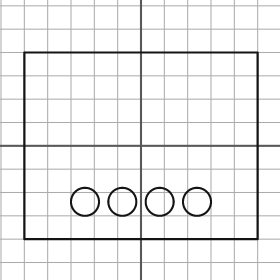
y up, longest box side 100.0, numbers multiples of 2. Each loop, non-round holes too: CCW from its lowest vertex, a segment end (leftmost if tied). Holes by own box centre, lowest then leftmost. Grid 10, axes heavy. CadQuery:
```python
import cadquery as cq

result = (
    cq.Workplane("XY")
    .moveTo(-50.0, -40.0)
    .lineTo(50.0, -40.0)
    .lineTo(50.0, 40.0)
    .lineTo(-50.0, 40.0)
    .close()
    .moveTo(-24.0, -24.0)
    .circle(6.0)
    .moveTo(-8.0, -24.0)
    .circle(6.0)
    .moveTo(8.0, -24.0)
    .circle(6.0)
    .moveTo(24.0, -24.0)
    .circle(6.0)
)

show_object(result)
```